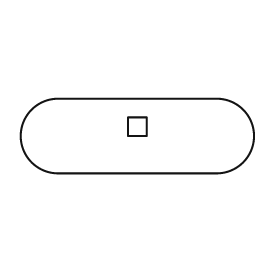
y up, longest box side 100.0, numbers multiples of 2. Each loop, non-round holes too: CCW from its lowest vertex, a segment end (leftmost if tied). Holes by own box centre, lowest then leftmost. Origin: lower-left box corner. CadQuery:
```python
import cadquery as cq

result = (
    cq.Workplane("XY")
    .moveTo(16.0, 0.0)
    .lineTo(84.0, 0.0)
    .threePointArc((100.0, 16.0), (84.0, 32.0))
    .lineTo(16.0, 32.0)
    .threePointArc((0.0, 16.0), (16.0, 0.0))
    .close()
    .moveTo(46.0, 16.0)
    .lineTo(54.0, 16.0)
    .lineTo(54.0, 24.0)
    .lineTo(46.0, 24.0)
    .close()
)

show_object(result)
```